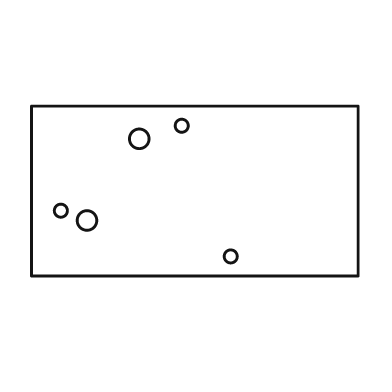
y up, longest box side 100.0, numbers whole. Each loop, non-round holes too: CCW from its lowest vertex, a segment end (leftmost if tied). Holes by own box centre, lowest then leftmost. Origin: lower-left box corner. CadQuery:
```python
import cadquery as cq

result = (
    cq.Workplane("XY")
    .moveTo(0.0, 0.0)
    .lineTo(100.0, 0.0)
    .lineTo(100.0, 52.0)
    .lineTo(0.0, 52.0)
    .close()
    .moveTo(61.0, 6.0)
    .circle(2.0)
    .moveTo(17.0, 17.0)
    .circle(3.0)
    .moveTo(9.0, 20.0)
    .circle(2.0)
    .moveTo(33.0, 42.0)
    .circle(3.0)
    .moveTo(46.0, 46.0)
    .circle(2.0)
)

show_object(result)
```